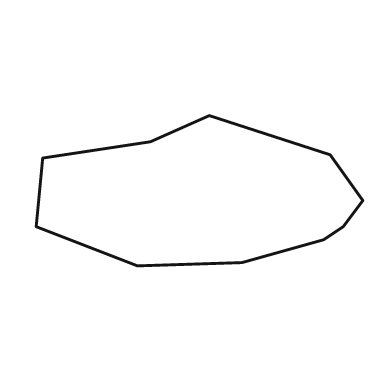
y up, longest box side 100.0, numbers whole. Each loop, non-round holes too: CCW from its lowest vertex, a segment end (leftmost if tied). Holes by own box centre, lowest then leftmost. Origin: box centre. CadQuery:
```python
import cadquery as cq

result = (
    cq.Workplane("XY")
    .moveTo(-19.0, -23.0)
    .lineTo(13.0, -22.0)
    .lineTo(38.0, -15.0)
    .lineTo(44.0, -11.0)
    .lineTo(50.0, -3.0)
    .lineTo(40.0, 11.0)
    .lineTo(3.0, 23.0)
    .lineTo(-15.0, 15.0)
    .lineTo(-48.0, 10.0)
    .lineTo(-50.0, -11.0)
    .close()
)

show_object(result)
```